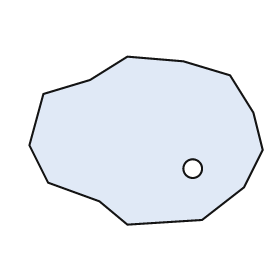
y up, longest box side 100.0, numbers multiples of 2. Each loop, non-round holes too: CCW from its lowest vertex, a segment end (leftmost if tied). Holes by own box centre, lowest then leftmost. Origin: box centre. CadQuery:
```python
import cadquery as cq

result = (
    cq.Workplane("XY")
    .moveTo(-8.0, -36.0)
    .lineTo(24.0, -34.0)
    .lineTo(42.0, -20.0)
    .lineTo(50.0, -4.0)
    .lineTo(46.0, 12.0)
    .lineTo(36.0, 28.0)
    .lineTo(16.0, 34.0)
    .lineTo(-8.0, 36.0)
    .lineTo(-24.0, 26.0)
    .lineTo(-44.0, 20.0)
    .lineTo(-50.0, -2.0)
    .lineTo(-42.0, -18.0)
    .lineTo(-20.0, -26.0)
    .close()
    .moveTo(20.0, -12.0)
    .circle(4.0)
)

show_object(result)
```